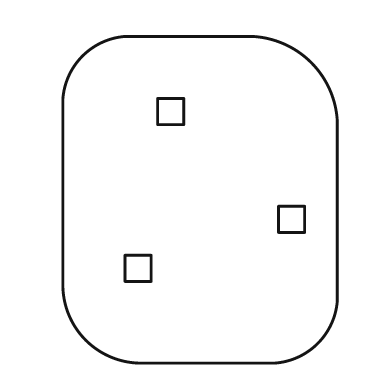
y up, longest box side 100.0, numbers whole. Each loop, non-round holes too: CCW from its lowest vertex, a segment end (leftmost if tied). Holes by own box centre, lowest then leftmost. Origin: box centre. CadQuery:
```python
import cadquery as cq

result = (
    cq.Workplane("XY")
    .moveTo(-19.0, -50.0)
    .lineTo(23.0, -50.0)
    .threePointArc((36.0, -44.0), (42.0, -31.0))
    .lineTo(42.0, 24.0)
    .threePointArc((34.0, 42.0), (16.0, 50.0))
    .lineTo(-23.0, 50.0)
    .threePointArc((-36.0, 44.0), (-42.0, 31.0))
    .lineTo(-42.0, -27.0)
    .threePointArc((-35.0, -43.0), (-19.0, -50.0))
    .close()
    .moveTo(-23.0, -25.0)
    .lineTo(-15.0, -25.0)
    .lineTo(-15.0, -17.0)
    .lineTo(-23.0, -17.0)
    .close()
    .moveTo(24.0, -10.0)
    .lineTo(32.0, -10.0)
    .lineTo(32.0, -2.0)
    .lineTo(24.0, -2.0)
    .close()
    .moveTo(-13.0, 23.0)
    .lineTo(-5.0, 23.0)
    .lineTo(-5.0, 31.0)
    .lineTo(-13.0, 31.0)
    .close()
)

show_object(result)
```